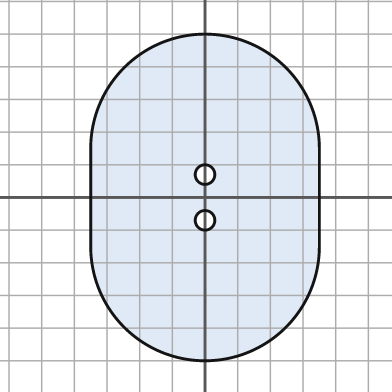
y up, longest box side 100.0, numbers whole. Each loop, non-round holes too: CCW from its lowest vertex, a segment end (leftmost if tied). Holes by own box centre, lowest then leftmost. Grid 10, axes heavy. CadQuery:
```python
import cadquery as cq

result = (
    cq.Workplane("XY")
    .moveTo(-35.0, -15.0)
    .threePointArc((0.0, -50.0), (35.0, -15.0))
    .lineTo(35.0, 15.0)
    .threePointArc((0.0, 50.0), (-35.0, 15.0))
    .close()
    .moveTo(0.0, -7.0)
    .circle(3.0)
    .moveTo(0.0, 7.0)
    .circle(3.0)
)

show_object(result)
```